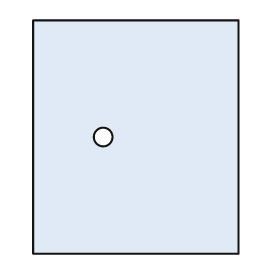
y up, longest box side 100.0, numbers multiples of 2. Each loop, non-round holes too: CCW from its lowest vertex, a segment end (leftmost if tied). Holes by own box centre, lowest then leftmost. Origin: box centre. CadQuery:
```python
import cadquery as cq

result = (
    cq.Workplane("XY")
    .moveTo(-44.0, -50.0)
    .lineTo(44.0, -50.0)
    .lineTo(44.0, 50.0)
    .lineTo(-44.0, 50.0)
    .close()
    .moveTo(-14.0, 0.0)
    .circle(4.0)
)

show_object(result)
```